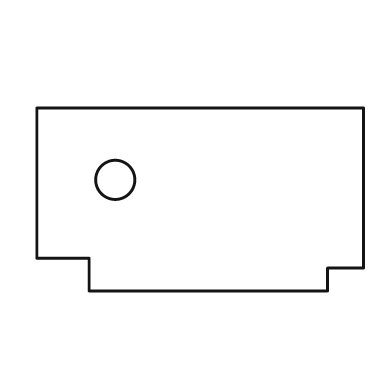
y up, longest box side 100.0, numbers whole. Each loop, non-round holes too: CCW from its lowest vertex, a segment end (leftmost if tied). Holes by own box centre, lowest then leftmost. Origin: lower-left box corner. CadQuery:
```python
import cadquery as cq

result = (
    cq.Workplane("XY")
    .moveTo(16.0, 0.0)
    .lineTo(89.0, 0.0)
    .lineTo(89.0, 7.0)
    .lineTo(100.0, 7.0)
    .lineTo(100.0, 56.0)
    .lineTo(0.0, 56.0)
    .lineTo(0.0, 10.0)
    .lineTo(16.0, 10.0)
    .close()
    .moveTo(24.0, 34.0)
    .circle(6.0)
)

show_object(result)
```